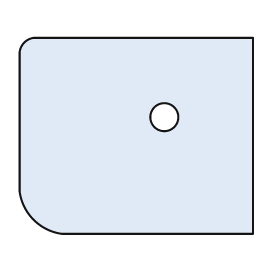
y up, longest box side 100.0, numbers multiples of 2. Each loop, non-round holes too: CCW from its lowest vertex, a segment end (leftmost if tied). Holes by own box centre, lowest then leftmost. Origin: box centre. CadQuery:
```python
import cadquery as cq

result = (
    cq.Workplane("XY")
    .moveTo(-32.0, -42.0)
    .lineTo(50.0, -42.0)
    .lineTo(50.0, 42.0)
    .lineTo(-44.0, 42.0)
    .threePointArc((-48.0, 40.0), (-50.0, 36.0))
    .lineTo(-50.0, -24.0)
    .threePointArc((-44.0, -36.0), (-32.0, -42.0))
    .close()
    .moveTo(12.0, 8.0)
    .circle(6.0)
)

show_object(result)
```